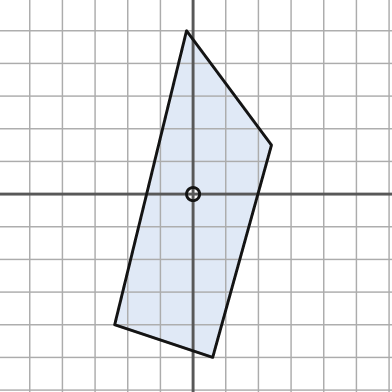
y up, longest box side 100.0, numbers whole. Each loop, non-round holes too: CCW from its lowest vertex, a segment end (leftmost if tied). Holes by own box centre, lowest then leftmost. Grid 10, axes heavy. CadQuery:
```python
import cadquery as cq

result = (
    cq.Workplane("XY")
    .moveTo(6.0, -50.0)
    .lineTo(24.0, 15.0)
    .lineTo(-2.0, 50.0)
    .lineTo(-24.0, -40.0)
    .close()
    .moveTo(0.0, 0.0)
    .circle(2.0)
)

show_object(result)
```